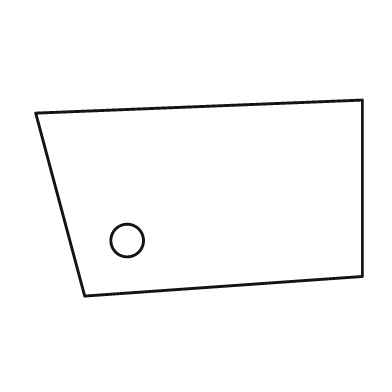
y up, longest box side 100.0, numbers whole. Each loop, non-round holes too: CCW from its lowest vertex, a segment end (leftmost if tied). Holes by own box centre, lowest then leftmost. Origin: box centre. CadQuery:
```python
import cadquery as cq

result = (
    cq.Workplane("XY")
    .moveTo(-35.0, -30.0)
    .lineTo(50.0, -24.0)
    .lineTo(50.0, 30.0)
    .lineTo(-50.0, 26.0)
    .close()
    .moveTo(-22.0, -13.0)
    .circle(5.0)
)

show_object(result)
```